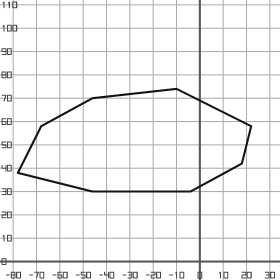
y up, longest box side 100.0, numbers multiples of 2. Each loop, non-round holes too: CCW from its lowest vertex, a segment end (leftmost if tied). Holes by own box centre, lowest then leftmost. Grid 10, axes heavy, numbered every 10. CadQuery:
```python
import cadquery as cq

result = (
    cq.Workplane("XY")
    .moveTo(-46.0, 30.0)
    .lineTo(-4.0, 30.0)
    .lineTo(18.0, 42.0)
    .lineTo(22.0, 58.0)
    .lineTo(-10.0, 74.0)
    .lineTo(-46.0, 70.0)
    .lineTo(-68.0, 58.0)
    .lineTo(-78.0, 38.0)
    .close()
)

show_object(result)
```